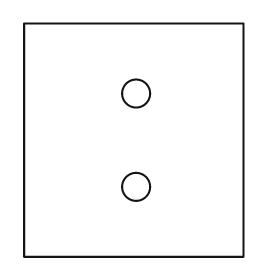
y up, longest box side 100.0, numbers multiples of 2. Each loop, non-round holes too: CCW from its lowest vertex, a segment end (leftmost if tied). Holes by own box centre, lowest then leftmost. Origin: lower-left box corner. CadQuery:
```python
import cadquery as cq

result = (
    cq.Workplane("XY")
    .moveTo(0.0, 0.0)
    .lineTo(94.0, 0.0)
    .lineTo(94.0, 100.0)
    .lineTo(0.0, 100.0)
    .close()
    .moveTo(48.0, 30.0)
    .circle(6.0)
    .moveTo(48.0, 70.0)
    .circle(6.0)
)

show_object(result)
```